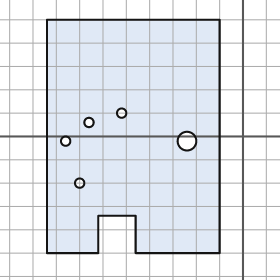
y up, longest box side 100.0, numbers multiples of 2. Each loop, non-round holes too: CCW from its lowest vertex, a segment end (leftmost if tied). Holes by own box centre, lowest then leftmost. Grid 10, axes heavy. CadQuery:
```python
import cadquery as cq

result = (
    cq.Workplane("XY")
    .moveTo(-84.0, -50.0)
    .lineTo(-62.0, -50.0)
    .lineTo(-62.0, -34.0)
    .lineTo(-46.0, -34.0)
    .lineTo(-46.0, -50.0)
    .lineTo(-10.0, -50.0)
    .lineTo(-10.0, 50.0)
    .lineTo(-84.0, 50.0)
    .close()
    .moveTo(-70.0, -20.0)
    .circle(2.0)
    .moveTo(-76.0, -2.0)
    .circle(2.0)
    .moveTo(-24.0, -2.0)
    .circle(4.0)
    .moveTo(-66.0, 6.0)
    .circle(2.0)
    .moveTo(-52.0, 10.0)
    .circle(2.0)
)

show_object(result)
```